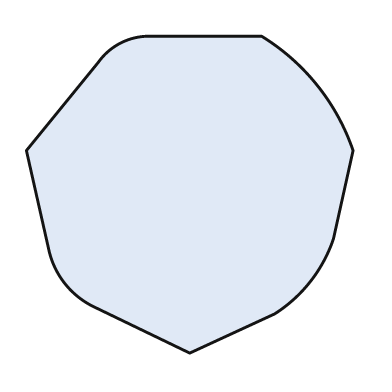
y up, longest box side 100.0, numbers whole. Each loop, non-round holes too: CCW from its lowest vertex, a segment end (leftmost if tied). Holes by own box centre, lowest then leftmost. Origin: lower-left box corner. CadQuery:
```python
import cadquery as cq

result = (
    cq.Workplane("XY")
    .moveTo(50.0, 0.0)
    .lineTo(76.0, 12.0)
    .threePointArc((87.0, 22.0), (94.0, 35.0))
    .lineTo(100.0, 62.0)
    .threePointArc((89.0, 82.0), (72.0, 97.0))
    .lineTo(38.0, 97.0)
    .threePointArc((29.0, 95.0), (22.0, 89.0))
    .lineTo(0.0, 62.0)
    .lineTo(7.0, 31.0)
    .threePointArc((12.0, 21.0), (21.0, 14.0))
    .close()
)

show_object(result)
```